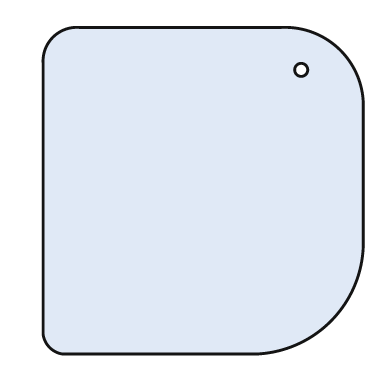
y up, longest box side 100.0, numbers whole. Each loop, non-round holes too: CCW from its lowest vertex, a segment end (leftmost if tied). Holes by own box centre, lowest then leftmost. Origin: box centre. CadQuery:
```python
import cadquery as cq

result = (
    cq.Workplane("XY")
    .moveTo(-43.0, -50.0)
    .lineTo(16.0, -50.0)
    .threePointArc((39.0, -40.0), (49.0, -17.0))
    .lineTo(49.0, 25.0)
    .threePointArc((42.0, 43.0), (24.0, 50.0))
    .lineTo(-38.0, 50.0)
    .threePointArc((-46.0, 47.0), (-49.0, 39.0))
    .lineTo(-49.0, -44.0)
    .threePointArc((-47.0, -48.0), (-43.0, -50.0))
    .close()
    .moveTo(30.0, 37.0)
    .circle(2.0)
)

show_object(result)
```